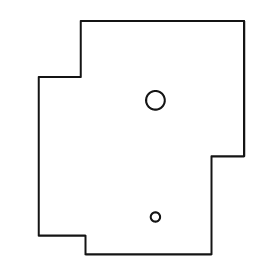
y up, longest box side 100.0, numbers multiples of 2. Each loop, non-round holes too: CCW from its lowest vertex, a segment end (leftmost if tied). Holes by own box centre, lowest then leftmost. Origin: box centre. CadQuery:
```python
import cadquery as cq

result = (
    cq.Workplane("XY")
    .moveTo(-24.0, -50.0)
    .lineTo(30.0, -50.0)
    .lineTo(30.0, -8.0)
    .lineTo(44.0, -8.0)
    .lineTo(44.0, 50.0)
    .lineTo(-26.0, 50.0)
    .lineTo(-26.0, 26.0)
    .lineTo(-44.0, 26.0)
    .lineTo(-44.0, -42.0)
    .lineTo(-24.0, -42.0)
    .close()
    .moveTo(6.0, -34.0)
    .circle(2.0)
    .moveTo(6.0, 16.0)
    .circle(4.0)
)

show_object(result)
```